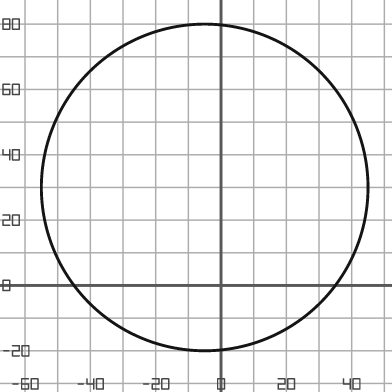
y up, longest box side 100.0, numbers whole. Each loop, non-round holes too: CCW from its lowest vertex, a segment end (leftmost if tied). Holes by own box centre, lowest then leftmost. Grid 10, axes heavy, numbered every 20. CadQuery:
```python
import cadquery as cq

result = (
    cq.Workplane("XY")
    .moveTo(-5.0, 30.0)
    .circle(50.0)
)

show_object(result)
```